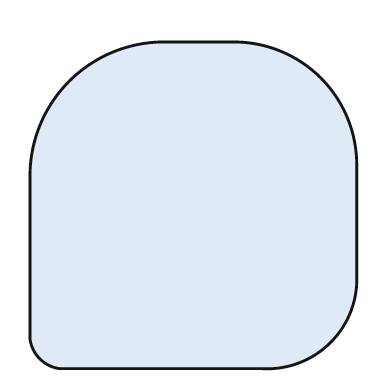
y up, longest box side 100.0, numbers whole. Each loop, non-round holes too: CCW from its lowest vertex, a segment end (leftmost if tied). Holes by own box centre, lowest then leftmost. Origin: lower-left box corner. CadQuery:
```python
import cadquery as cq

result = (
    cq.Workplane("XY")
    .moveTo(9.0, 0.0)
    .lineTo(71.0, 0.0)
    .threePointArc((92.0, 8.0), (100.0, 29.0))
    .lineTo(100.0, 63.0)
    .threePointArc((89.0, 89.0), (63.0, 100.0))
    .lineTo(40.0, 100.0)
    .threePointArc((12.0, 88.0), (0.0, 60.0))
    .lineTo(0.0, 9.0)
    .threePointArc((3.0, 3.0), (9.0, 0.0))
    .close()
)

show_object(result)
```